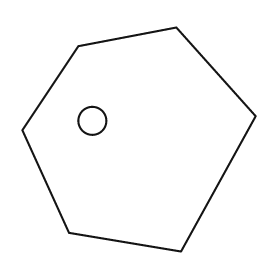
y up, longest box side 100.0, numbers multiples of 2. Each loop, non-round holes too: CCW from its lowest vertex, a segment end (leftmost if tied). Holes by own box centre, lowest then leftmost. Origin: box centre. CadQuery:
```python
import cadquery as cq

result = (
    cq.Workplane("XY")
    .moveTo(18.0, -48.0)
    .lineTo(50.0, 10.0)
    .lineTo(16.0, 48.0)
    .lineTo(-26.0, 40.0)
    .lineTo(-50.0, 4.0)
    .lineTo(-30.0, -40.0)
    .close()
    .moveTo(-20.0, 8.0)
    .circle(6.0)
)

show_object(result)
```